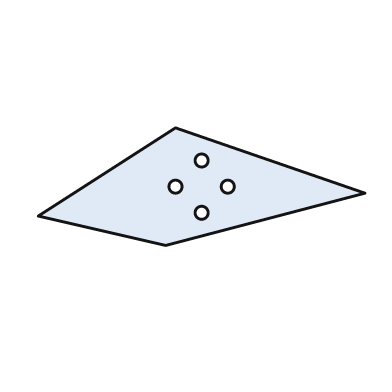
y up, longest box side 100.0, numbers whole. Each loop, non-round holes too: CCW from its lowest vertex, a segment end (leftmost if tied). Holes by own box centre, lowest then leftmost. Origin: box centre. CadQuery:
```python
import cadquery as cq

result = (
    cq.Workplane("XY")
    .moveTo(-11.0, -18.0)
    .lineTo(50.0, -2.0)
    .lineTo(-8.0, 18.0)
    .lineTo(-50.0, -9.0)
    .close()
    .moveTo(0.0, -8.0)
    .circle(2.0)
    .moveTo(-8.0, 0.0)
    .circle(2.0)
    .moveTo(8.0, 0.0)
    .circle(2.0)
    .moveTo(0.0, 8.0)
    .circle(2.0)
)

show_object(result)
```